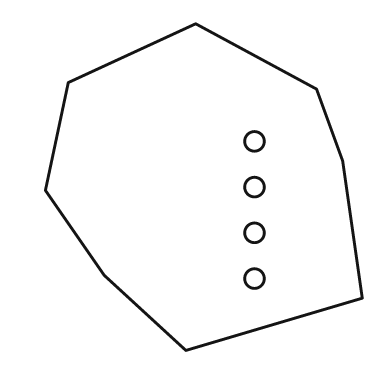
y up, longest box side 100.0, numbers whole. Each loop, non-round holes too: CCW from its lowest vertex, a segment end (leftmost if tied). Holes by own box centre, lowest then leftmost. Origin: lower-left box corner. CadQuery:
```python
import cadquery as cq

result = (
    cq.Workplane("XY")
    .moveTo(43.0, 0.0)
    .lineTo(97.0, 16.0)
    .lineTo(91.0, 58.0)
    .lineTo(83.0, 80.0)
    .lineTo(46.0, 100.0)
    .lineTo(7.0, 82.0)
    .lineTo(0.0, 49.0)
    .lineTo(18.0, 23.0)
    .close()
    .moveTo(64.0, 22.0)
    .circle(3.0)
    .moveTo(64.0, 36.0)
    .circle(3.0)
    .moveTo(64.0, 50.0)
    .circle(3.0)
    .moveTo(64.0, 64.0)
    .circle(3.0)
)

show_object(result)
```